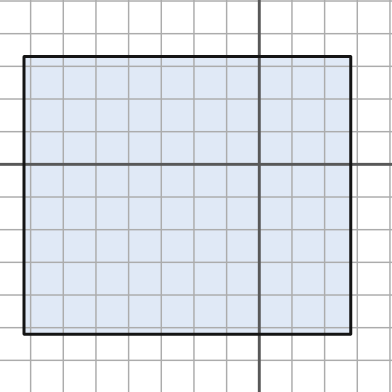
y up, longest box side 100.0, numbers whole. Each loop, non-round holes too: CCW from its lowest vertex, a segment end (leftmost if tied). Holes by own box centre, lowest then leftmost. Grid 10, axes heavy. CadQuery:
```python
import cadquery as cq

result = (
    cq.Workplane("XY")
    .moveTo(-72.0, -52.0)
    .lineTo(28.0, -52.0)
    .lineTo(28.0, 33.0)
    .lineTo(-72.0, 33.0)
    .close()
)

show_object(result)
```